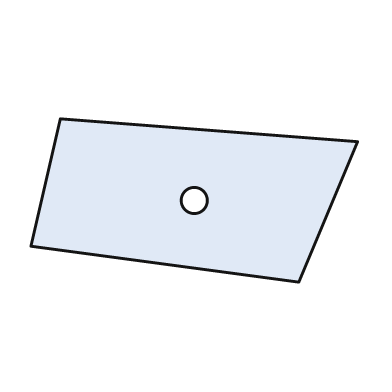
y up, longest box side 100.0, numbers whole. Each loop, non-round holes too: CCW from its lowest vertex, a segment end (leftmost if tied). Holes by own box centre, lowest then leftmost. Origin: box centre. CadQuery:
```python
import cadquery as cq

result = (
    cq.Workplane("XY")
    .moveTo(32.0, -25.0)
    .lineTo(50.0, 18.0)
    .lineTo(-41.0, 25.0)
    .lineTo(-50.0, -14.0)
    .close()
    .moveTo(0.0, 0.0)
    .circle(4.0)
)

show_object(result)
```